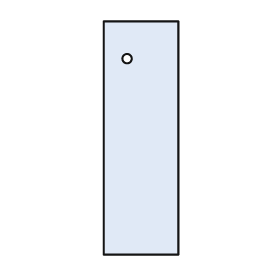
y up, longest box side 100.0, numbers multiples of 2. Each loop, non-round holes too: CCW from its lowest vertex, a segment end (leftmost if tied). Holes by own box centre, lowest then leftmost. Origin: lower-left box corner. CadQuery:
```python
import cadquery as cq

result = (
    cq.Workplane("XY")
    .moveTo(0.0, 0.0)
    .lineTo(32.0, 0.0)
    .lineTo(32.0, 100.0)
    .lineTo(0.0, 100.0)
    .close()
    .moveTo(10.0, 84.0)
    .circle(2.0)
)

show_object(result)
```